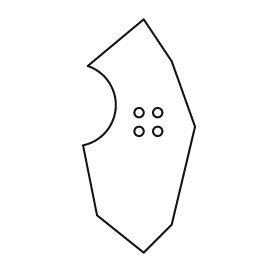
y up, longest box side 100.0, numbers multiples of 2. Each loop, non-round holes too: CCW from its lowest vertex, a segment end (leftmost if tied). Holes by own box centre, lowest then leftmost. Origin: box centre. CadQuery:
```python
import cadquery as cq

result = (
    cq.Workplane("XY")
    .moveTo(2.0, -50.0)
    .lineTo(14.0, -38.0)
    .lineTo(24.0, 4.0)
    .lineTo(14.0, 32.0)
    .lineTo(2.0, 50.0)
    .lineTo(-22.0, 30.0)
    .threePointArc((-10.0, 12.0), (-24.0, -4.0))
    .lineTo(-18.0, -34.0)
    .close()
    .moveTo(0.0, 2.0)
    .circle(2.0)
    .moveTo(8.0, 2.0)
    .circle(2.0)
    .moveTo(0.0, 10.0)
    .circle(2.0)
    .moveTo(8.0, 10.0)
    .circle(2.0)
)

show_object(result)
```